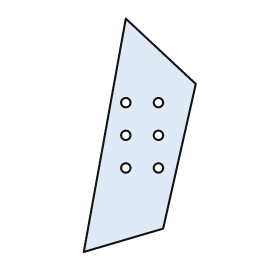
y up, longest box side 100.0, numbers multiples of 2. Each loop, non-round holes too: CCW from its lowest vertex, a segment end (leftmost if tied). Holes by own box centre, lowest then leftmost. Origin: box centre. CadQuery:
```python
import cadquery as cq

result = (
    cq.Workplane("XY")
    .moveTo(-24.0, -50.0)
    .lineTo(10.0, -40.0)
    .lineTo(24.0, 22.0)
    .lineTo(-6.0, 50.0)
    .close()
    .moveTo(-6.0, -14.0)
    .circle(2.0)
    .moveTo(8.0, -14.0)
    .circle(2.0)
    .moveTo(-6.0, 0.0)
    .circle(2.0)
    .moveTo(8.0, 0.0)
    .circle(2.0)
    .moveTo(-6.0, 14.0)
    .circle(2.0)
    .moveTo(8.0, 14.0)
    .circle(2.0)
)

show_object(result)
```